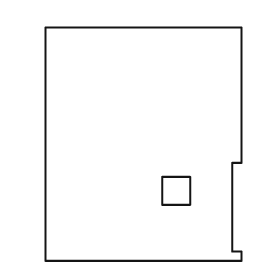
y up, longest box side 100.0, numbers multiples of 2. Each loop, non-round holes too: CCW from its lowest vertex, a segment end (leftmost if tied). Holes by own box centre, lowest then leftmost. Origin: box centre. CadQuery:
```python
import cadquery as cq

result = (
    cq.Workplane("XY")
    .moveTo(-42.0, -50.0)
    .lineTo(42.0, -50.0)
    .lineTo(42.0, -46.0)
    .lineTo(38.0, -46.0)
    .lineTo(38.0, -8.0)
    .lineTo(42.0, -8.0)
    .lineTo(42.0, 50.0)
    .lineTo(-42.0, 50.0)
    .close()
    .moveTo(8.0, -26.0)
    .lineTo(20.0, -26.0)
    .lineTo(20.0, -14.0)
    .lineTo(8.0, -14.0)
    .close()
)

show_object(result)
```